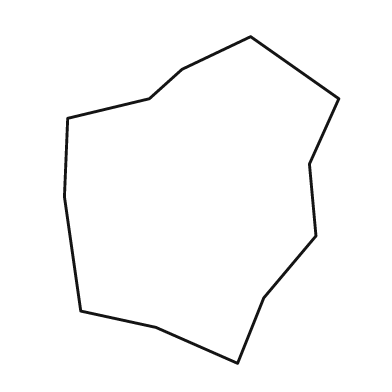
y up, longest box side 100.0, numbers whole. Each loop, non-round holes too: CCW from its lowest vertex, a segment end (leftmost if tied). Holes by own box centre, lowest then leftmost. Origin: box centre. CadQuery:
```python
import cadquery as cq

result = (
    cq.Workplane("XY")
    .moveTo(11.0, -50.0)
    .lineTo(19.0, -30.0)
    .lineTo(35.0, -11.0)
    .lineTo(33.0, 11.0)
    .lineTo(42.0, 31.0)
    .lineTo(15.0, 50.0)
    .lineTo(-6.0, 40.0)
    .lineTo(-16.0, 31.0)
    .lineTo(-41.0, 25.0)
    .lineTo(-42.0, 1.0)
    .lineTo(-37.0, -34.0)
    .lineTo(-14.0, -39.0)
    .close()
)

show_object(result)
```